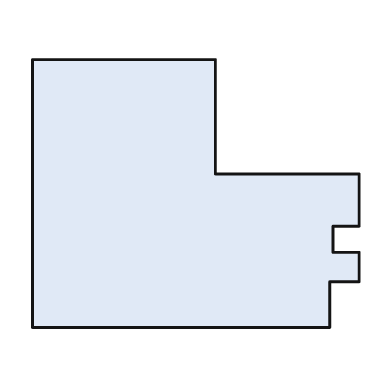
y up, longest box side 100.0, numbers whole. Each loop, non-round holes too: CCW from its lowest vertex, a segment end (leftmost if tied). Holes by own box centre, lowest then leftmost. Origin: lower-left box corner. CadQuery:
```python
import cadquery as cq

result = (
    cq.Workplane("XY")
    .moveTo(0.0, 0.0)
    .lineTo(91.0, 0.0)
    .lineTo(91.0, 14.0)
    .lineTo(100.0, 14.0)
    .lineTo(100.0, 23.0)
    .lineTo(92.0, 23.0)
    .lineTo(92.0, 31.0)
    .lineTo(100.0, 31.0)
    .lineTo(100.0, 47.0)
    .lineTo(56.0, 47.0)
    .lineTo(56.0, 82.0)
    .lineTo(0.0, 82.0)
    .close()
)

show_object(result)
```